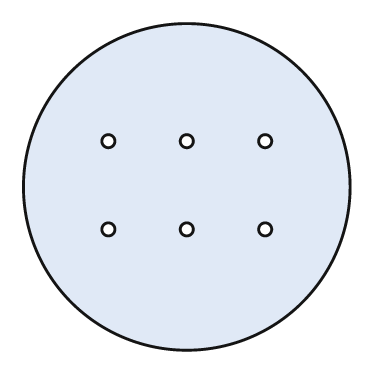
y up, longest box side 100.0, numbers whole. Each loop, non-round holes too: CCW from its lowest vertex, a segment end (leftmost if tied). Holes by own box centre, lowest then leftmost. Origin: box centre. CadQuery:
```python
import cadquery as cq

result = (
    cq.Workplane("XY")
    .moveTo(0.0, 0.0)
    .circle(50.0)
    .moveTo(-24.0, -13.0)
    .circle(2.0)
    .moveTo(0.0, -13.0)
    .circle(2.0)
    .moveTo(24.0, -13.0)
    .circle(2.0)
    .moveTo(-24.0, 14.0)
    .circle(2.0)
    .moveTo(0.0, 14.0)
    .circle(2.0)
    .moveTo(24.0, 14.0)
    .circle(2.0)
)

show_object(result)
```